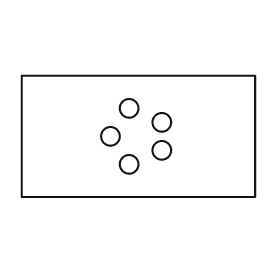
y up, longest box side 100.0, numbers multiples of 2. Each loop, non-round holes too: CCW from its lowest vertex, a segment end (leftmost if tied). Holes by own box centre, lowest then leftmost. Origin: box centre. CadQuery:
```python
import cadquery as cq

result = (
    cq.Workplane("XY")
    .moveTo(-50.0, -26.0)
    .lineTo(50.0, -26.0)
    .lineTo(50.0, 26.0)
    .lineTo(-50.0, 26.0)
    .close()
    .moveTo(-4.0, -12.0)
    .circle(4.0)
    .moveTo(10.0, -6.0)
    .circle(4.0)
    .moveTo(-12.0, 0.0)
    .circle(4.0)
    .moveTo(10.0, 6.0)
    .circle(4.0)
    .moveTo(-4.0, 12.0)
    .circle(4.0)
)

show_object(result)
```